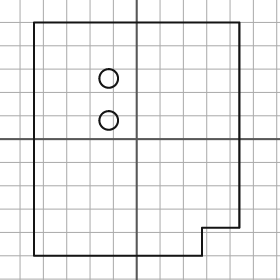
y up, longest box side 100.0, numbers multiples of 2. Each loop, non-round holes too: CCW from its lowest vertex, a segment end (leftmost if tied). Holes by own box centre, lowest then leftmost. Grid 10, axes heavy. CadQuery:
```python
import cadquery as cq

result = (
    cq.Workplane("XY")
    .moveTo(-44.0, -50.0)
    .lineTo(28.0, -50.0)
    .lineTo(28.0, -38.0)
    .lineTo(44.0, -38.0)
    .lineTo(44.0, 50.0)
    .lineTo(-44.0, 50.0)
    .close()
    .moveTo(-12.0, 8.0)
    .circle(4.0)
    .moveTo(-12.0, 26.0)
    .circle(4.0)
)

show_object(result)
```